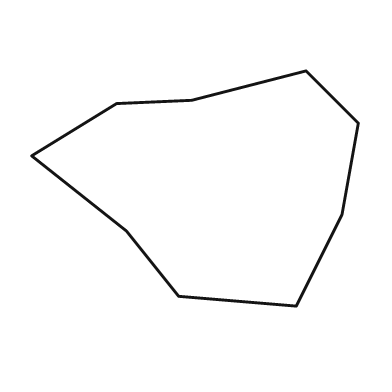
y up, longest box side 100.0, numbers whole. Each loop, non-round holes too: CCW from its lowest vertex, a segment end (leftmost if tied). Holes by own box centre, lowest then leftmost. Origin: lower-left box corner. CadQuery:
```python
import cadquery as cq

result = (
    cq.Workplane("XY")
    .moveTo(81.0, 0.0)
    .lineTo(95.0, 28.0)
    .lineTo(100.0, 56.0)
    .lineTo(84.0, 72.0)
    .lineTo(49.0, 63.0)
    .lineTo(26.0, 62.0)
    .lineTo(0.0, 46.0)
    .lineTo(29.0, 23.0)
    .lineTo(45.0, 3.0)
    .close()
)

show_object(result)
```